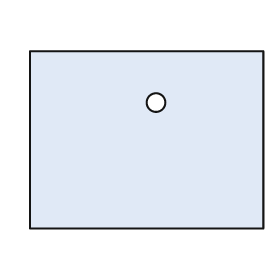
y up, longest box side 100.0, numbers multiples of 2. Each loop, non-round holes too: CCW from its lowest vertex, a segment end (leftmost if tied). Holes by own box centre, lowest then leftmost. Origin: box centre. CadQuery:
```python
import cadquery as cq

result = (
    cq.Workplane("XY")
    .moveTo(-50.0, -38.0)
    .lineTo(50.0, -38.0)
    .lineTo(50.0, 38.0)
    .lineTo(-50.0, 38.0)
    .close()
    .moveTo(4.0, 16.0)
    .circle(4.0)
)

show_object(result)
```